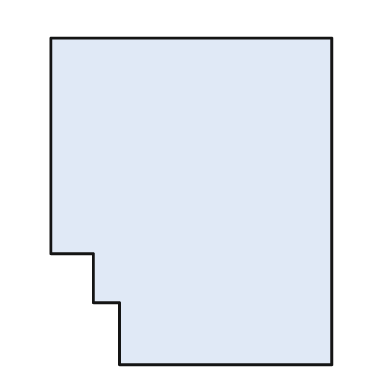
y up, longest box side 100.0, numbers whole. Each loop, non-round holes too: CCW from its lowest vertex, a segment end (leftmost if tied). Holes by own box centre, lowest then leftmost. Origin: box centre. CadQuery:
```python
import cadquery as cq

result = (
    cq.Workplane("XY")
    .moveTo(-22.0, -50.0)
    .lineTo(43.0, -50.0)
    .lineTo(43.0, 50.0)
    .lineTo(-43.0, 50.0)
    .lineTo(-43.0, -16.0)
    .lineTo(-30.0, -16.0)
    .lineTo(-30.0, -31.0)
    .lineTo(-22.0, -31.0)
    .close()
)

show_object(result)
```